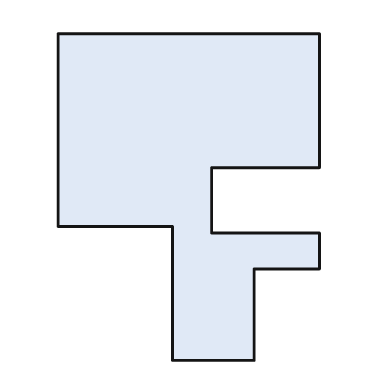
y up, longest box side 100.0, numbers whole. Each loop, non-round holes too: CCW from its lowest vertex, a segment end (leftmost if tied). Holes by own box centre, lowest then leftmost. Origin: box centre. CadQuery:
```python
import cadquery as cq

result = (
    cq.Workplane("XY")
    .moveTo(-5.0, -50.0)
    .lineTo(20.0, -50.0)
    .lineTo(20.0, -22.0)
    .lineTo(40.0, -22.0)
    .lineTo(40.0, -11.0)
    .lineTo(7.0, -11.0)
    .lineTo(7.0, 9.0)
    .lineTo(40.0, 9.0)
    .lineTo(40.0, 50.0)
    .lineTo(-40.0, 50.0)
    .lineTo(-40.0, -9.0)
    .lineTo(-5.0, -9.0)
    .close()
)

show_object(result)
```